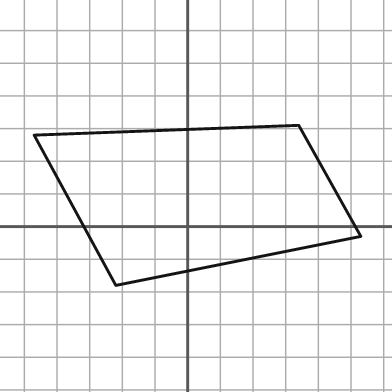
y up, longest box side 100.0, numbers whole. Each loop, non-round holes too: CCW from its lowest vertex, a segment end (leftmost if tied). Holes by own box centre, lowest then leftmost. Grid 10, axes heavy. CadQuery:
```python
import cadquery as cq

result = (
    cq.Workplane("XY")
    .moveTo(-22.0, -18.0)
    .lineTo(53.0, -3.0)
    .lineTo(34.0, 31.0)
    .lineTo(-47.0, 28.0)
    .close()
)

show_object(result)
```